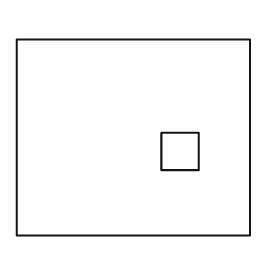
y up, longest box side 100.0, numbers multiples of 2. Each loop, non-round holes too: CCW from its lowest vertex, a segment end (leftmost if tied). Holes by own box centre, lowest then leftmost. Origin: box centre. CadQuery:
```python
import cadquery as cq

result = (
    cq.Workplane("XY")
    .moveTo(-50.0, -42.0)
    .lineTo(50.0, -42.0)
    .lineTo(50.0, 42.0)
    .lineTo(-50.0, 42.0)
    .close()
    .moveTo(12.0, -14.0)
    .lineTo(28.0, -14.0)
    .lineTo(28.0, 2.0)
    .lineTo(12.0, 2.0)
    .close()
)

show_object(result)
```